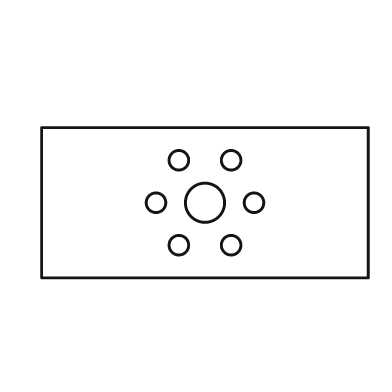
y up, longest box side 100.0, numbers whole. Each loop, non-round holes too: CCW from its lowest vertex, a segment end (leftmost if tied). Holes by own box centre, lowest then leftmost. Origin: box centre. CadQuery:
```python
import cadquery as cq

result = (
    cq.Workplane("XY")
    .moveTo(-50.0, -23.0)
    .lineTo(50.0, -23.0)
    .lineTo(50.0, 23.0)
    .lineTo(-50.0, 23.0)
    .close()
    .moveTo(-8.0, -13.0)
    .circle(3.0)
    .moveTo(8.0, -13.0)
    .circle(3.0)
    .moveTo(-15.0, 0.0)
    .circle(3.0)
    .moveTo(0.0, 0.0)
    .circle(6.0)
    .moveTo(15.0, 0.0)
    .circle(3.0)
    .moveTo(-8.0, 13.0)
    .circle(3.0)
    .moveTo(8.0, 13.0)
    .circle(3.0)
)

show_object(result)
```